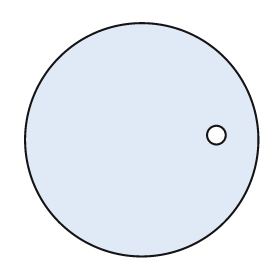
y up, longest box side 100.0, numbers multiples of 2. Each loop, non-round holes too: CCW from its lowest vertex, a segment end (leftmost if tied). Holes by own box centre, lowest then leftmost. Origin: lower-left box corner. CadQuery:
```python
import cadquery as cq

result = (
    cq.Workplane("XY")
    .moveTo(50.0, 50.0)
    .circle(50.0)
    .moveTo(82.0, 52.0)
    .circle(4.0)
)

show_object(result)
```